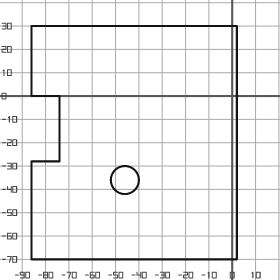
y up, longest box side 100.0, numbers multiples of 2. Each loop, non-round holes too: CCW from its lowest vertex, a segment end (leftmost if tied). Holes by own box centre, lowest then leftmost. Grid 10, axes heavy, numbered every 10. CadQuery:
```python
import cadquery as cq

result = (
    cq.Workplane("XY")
    .moveTo(-86.0, -70.0)
    .lineTo(2.0, -70.0)
    .lineTo(2.0, 30.0)
    .lineTo(-86.0, 30.0)
    .lineTo(-86.0, 0.0)
    .lineTo(-74.0, 0.0)
    .lineTo(-74.0, -28.0)
    .lineTo(-86.0, -28.0)
    .close()
    .moveTo(-46.0, -36.0)
    .circle(6.0)
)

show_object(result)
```